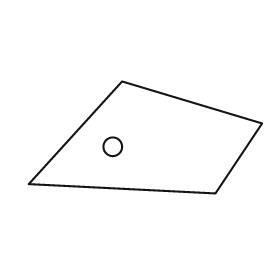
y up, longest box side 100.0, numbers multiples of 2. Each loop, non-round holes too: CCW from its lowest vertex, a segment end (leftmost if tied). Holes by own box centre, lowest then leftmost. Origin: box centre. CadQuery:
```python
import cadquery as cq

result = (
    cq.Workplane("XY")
    .moveTo(30.0, -24.0)
    .lineTo(50.0, 6.0)
    .lineTo(-10.0, 24.0)
    .lineTo(-50.0, -20.0)
    .close()
    .moveTo(-14.0, -4.0)
    .circle(4.0)
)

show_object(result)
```